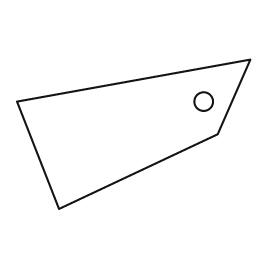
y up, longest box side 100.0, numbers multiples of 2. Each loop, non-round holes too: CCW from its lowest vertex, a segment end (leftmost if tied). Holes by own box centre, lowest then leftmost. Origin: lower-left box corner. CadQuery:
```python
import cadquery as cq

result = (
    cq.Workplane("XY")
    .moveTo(18.0, 0.0)
    .lineTo(86.0, 32.0)
    .lineTo(100.0, 64.0)
    .lineTo(0.0, 46.0)
    .close()
    .moveTo(80.0, 46.0)
    .circle(4.0)
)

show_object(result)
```